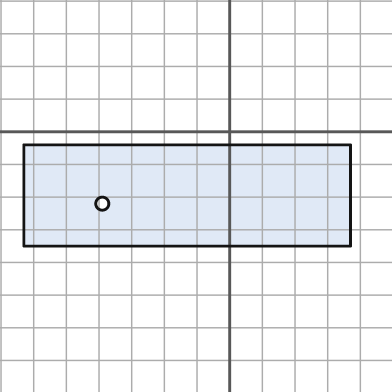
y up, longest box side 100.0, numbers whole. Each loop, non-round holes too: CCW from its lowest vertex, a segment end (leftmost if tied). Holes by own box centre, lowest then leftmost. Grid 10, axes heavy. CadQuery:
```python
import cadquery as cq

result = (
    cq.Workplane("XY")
    .moveTo(-63.0, -35.0)
    .lineTo(37.0, -35.0)
    .lineTo(37.0, -4.0)
    .lineTo(-63.0, -4.0)
    .close()
    .moveTo(-39.0, -22.0)
    .circle(2.0)
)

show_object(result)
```